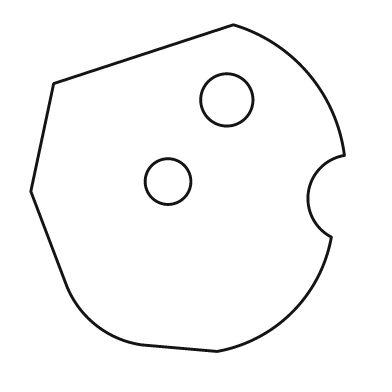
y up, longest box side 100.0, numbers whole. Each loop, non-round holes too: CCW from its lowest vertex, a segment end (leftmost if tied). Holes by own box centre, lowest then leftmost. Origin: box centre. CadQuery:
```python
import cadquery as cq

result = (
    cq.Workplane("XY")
    .moveTo(9.0, -50.0)
    .threePointArc((32.0, -38.0), (44.0, -15.0))
    .threePointArc((37.0, -1.0), (48.0, 10.0))
    .threePointArc((37.0, 35.0), (14.0, 50.0))
    .lineTo(-41.0, 32.0)
    .lineTo(-48.0, -1.0)
    .lineTo(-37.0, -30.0)
    .threePointArc((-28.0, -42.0), (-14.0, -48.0))
    .close()
    .moveTo(-6.0, 2.0)
    .circle(7.0)
    .moveTo(12.0, 27.0)
    .circle(8.0)
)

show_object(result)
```